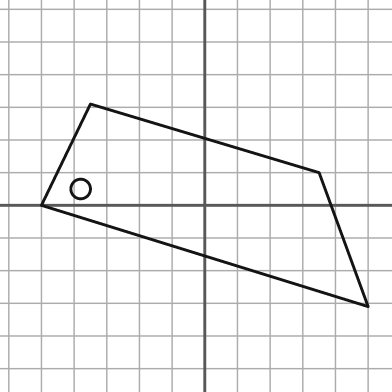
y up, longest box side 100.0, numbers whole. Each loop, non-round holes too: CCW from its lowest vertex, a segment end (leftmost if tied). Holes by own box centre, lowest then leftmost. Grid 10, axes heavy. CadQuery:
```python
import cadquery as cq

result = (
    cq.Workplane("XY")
    .moveTo(50.0, -31.0)
    .lineTo(35.0, 10.0)
    .lineTo(-35.0, 31.0)
    .lineTo(-50.0, 0.0)
    .close()
    .moveTo(-38.0, 5.0)
    .circle(3.0)
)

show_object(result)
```